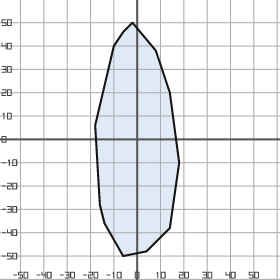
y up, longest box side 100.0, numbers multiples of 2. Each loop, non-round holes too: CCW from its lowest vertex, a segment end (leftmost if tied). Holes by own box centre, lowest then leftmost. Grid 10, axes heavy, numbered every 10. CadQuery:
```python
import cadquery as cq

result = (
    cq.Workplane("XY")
    .moveTo(-6.0, -50.0)
    .lineTo(4.0, -48.0)
    .lineTo(14.0, -38.0)
    .lineTo(18.0, -10.0)
    .lineTo(14.0, 20.0)
    .lineTo(8.0, 38.0)
    .lineTo(-2.0, 50.0)
    .lineTo(-6.0, 46.0)
    .lineTo(-10.0, 40.0)
    .lineTo(-18.0, 6.0)
    .lineTo(-16.0, -28.0)
    .lineTo(-14.0, -36.0)
    .close()
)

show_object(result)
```